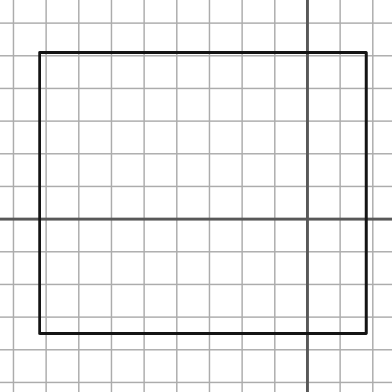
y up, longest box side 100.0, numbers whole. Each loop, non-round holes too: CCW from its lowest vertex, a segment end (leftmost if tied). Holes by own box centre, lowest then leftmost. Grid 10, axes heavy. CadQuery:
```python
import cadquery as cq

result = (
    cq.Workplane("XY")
    .moveTo(-82.0, -35.0)
    .lineTo(18.0, -35.0)
    .lineTo(18.0, 51.0)
    .lineTo(-82.0, 51.0)
    .close()
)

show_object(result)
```